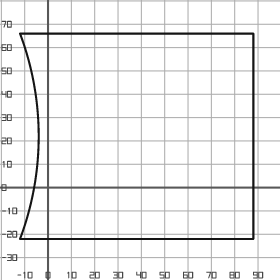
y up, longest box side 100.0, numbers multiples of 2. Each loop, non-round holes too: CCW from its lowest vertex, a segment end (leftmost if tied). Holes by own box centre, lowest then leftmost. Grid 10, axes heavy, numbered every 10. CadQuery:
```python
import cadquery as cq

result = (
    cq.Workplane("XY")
    .moveTo(-12.0, -22.0)
    .lineTo(88.0, -22.0)
    .lineTo(88.0, 66.0)
    .lineTo(-12.0, 66.0)
    .threePointArc((-4.0, 22.0), (-12.0, -22.0))
    .close()
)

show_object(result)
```